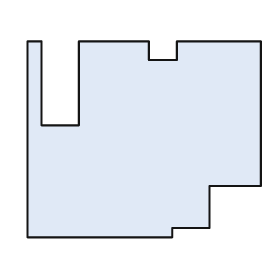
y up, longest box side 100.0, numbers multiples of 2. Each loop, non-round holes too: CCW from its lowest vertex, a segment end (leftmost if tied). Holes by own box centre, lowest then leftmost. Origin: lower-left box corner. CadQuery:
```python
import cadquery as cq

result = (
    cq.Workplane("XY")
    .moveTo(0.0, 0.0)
    .lineTo(62.0, 0.0)
    .lineTo(62.0, 4.0)
    .lineTo(78.0, 4.0)
    .lineTo(78.0, 22.0)
    .lineTo(100.0, 22.0)
    .lineTo(100.0, 84.0)
    .lineTo(64.0, 84.0)
    .lineTo(64.0, 76.0)
    .lineTo(52.0, 76.0)
    .lineTo(52.0, 84.0)
    .lineTo(22.0, 84.0)
    .lineTo(22.0, 48.0)
    .lineTo(6.0, 48.0)
    .lineTo(6.0, 84.0)
    .lineTo(0.0, 84.0)
    .close()
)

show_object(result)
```